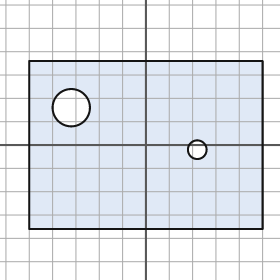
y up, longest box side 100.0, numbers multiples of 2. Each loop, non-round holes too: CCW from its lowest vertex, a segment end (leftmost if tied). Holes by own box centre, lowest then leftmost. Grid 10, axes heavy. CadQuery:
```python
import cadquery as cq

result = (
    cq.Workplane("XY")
    .moveTo(-50.0, -36.0)
    .lineTo(50.0, -36.0)
    .lineTo(50.0, 36.0)
    .lineTo(-50.0, 36.0)
    .close()
    .moveTo(22.0, -2.0)
    .circle(4.0)
    .moveTo(-32.0, 16.0)
    .circle(8.0)
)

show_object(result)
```